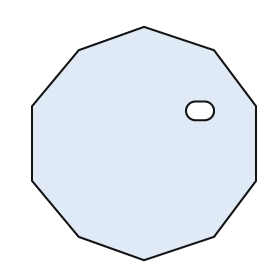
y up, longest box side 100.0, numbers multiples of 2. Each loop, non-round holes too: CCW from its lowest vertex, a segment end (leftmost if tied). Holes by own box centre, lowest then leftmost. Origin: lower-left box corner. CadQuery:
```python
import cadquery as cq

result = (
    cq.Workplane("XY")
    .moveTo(48.0, 0.0)
    .lineTo(78.0, 10.0)
    .lineTo(96.0, 34.0)
    .lineTo(96.0, 66.0)
    .lineTo(78.0, 90.0)
    .lineTo(48.0, 100.0)
    .lineTo(20.0, 90.0)
    .lineTo(0.0, 66.0)
    .lineTo(0.0, 34.0)
    .lineTo(20.0, 10.0)
    .close()
    .moveTo(70.0, 60.0)
    .lineTo(74.0, 60.0)
    .threePointArc((78.0, 64.0), (74.0, 68.0))
    .lineTo(70.0, 68.0)
    .threePointArc((66.0, 64.0), (70.0, 60.0))
    .close()
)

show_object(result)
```